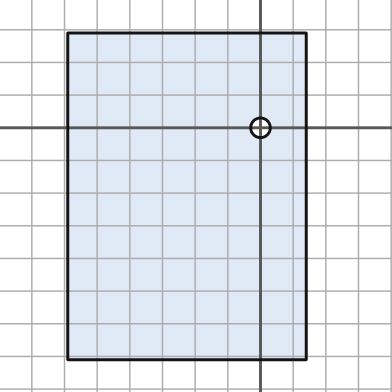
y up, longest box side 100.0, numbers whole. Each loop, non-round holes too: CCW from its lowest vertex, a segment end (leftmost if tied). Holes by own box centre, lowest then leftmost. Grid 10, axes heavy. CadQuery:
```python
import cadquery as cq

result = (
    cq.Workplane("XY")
    .moveTo(-59.0, -71.0)
    .lineTo(14.0, -71.0)
    .lineTo(14.0, 29.0)
    .lineTo(-59.0, 29.0)
    .close()
    .moveTo(0.0, 0.0)
    .circle(3.0)
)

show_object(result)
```